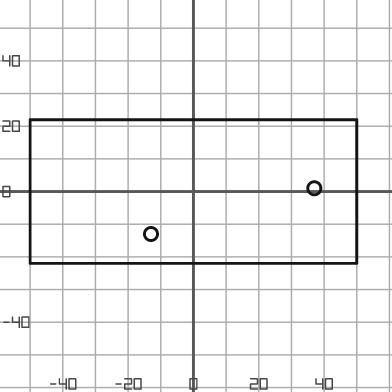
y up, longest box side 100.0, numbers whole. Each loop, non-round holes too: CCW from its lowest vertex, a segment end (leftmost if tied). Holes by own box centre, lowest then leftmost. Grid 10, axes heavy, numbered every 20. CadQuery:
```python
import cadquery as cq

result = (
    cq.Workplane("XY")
    .moveTo(-50.0, -22.0)
    .lineTo(50.0, -22.0)
    .lineTo(50.0, 22.0)
    .lineTo(-50.0, 22.0)
    .close()
    .moveTo(-13.0, -13.0)
    .circle(2.0)
    .moveTo(37.0, 1.0)
    .circle(2.0)
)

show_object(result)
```